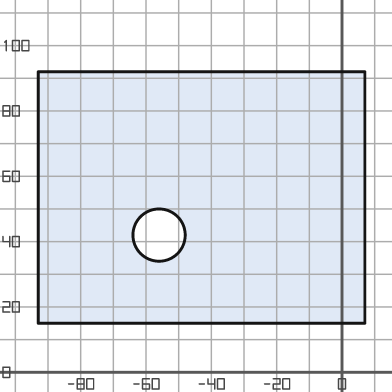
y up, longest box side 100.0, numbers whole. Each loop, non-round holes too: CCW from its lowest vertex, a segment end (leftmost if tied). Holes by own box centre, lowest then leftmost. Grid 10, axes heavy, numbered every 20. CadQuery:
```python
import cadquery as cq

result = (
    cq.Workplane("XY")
    .moveTo(-93.0, 15.0)
    .lineTo(7.0, 15.0)
    .lineTo(7.0, 92.0)
    .lineTo(-93.0, 92.0)
    .close()
    .moveTo(-56.0, 42.0)
    .circle(8.0)
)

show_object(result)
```